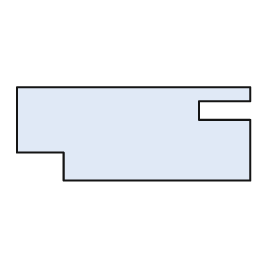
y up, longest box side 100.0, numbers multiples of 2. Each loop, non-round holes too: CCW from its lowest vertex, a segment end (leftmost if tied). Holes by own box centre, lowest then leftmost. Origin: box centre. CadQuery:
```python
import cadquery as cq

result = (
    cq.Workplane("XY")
    .moveTo(-30.0, -20.0)
    .lineTo(50.0, -20.0)
    .lineTo(50.0, 6.0)
    .lineTo(28.0, 6.0)
    .lineTo(28.0, 14.0)
    .lineTo(50.0, 14.0)
    .lineTo(50.0, 20.0)
    .lineTo(-50.0, 20.0)
    .lineTo(-50.0, -8.0)
    .lineTo(-30.0, -8.0)
    .close()
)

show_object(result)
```